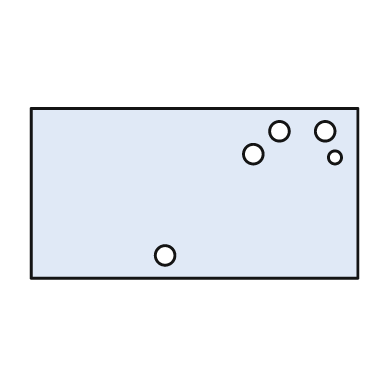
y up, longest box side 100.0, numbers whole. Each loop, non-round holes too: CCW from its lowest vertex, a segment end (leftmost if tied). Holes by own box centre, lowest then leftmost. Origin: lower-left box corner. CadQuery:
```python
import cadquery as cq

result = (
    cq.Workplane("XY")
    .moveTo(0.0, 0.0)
    .lineTo(100.0, 0.0)
    .lineTo(100.0, 52.0)
    .lineTo(0.0, 52.0)
    .close()
    .moveTo(41.0, 7.0)
    .circle(3.0)
    .moveTo(93.0, 37.0)
    .circle(2.0)
    .moveTo(68.0, 38.0)
    .circle(3.0)
    .moveTo(76.0, 45.0)
    .circle(3.0)
    .moveTo(90.0, 45.0)
    .circle(3.0)
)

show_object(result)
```